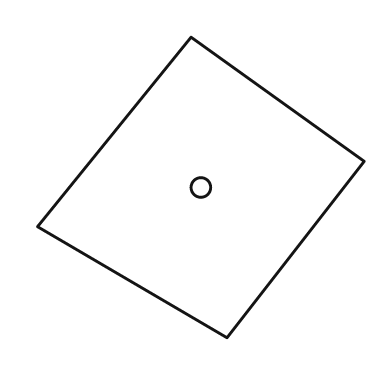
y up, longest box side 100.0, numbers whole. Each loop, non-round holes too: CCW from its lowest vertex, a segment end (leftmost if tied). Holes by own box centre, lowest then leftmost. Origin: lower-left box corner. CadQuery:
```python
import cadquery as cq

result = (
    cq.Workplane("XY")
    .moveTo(58.0, 0.0)
    .lineTo(100.0, 54.0)
    .lineTo(47.0, 92.0)
    .lineTo(0.0, 34.0)
    .close()
    .moveTo(50.0, 46.0)
    .circle(3.0)
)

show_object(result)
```